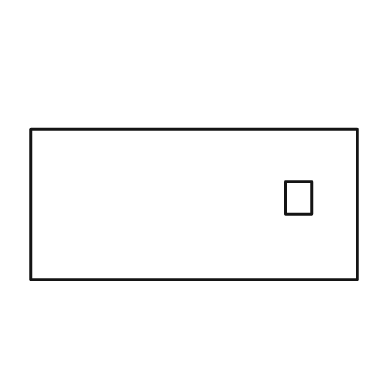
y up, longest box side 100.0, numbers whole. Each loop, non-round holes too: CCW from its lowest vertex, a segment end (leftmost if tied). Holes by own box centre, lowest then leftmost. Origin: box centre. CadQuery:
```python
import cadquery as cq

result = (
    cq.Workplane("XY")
    .moveTo(-50.0, -23.0)
    .lineTo(50.0, -23.0)
    .lineTo(50.0, 23.0)
    .lineTo(-50.0, 23.0)
    .close()
    .moveTo(28.0, -3.0)
    .lineTo(36.0, -3.0)
    .lineTo(36.0, 7.0)
    .lineTo(28.0, 7.0)
    .close()
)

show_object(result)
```